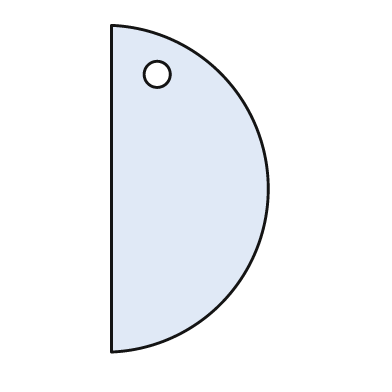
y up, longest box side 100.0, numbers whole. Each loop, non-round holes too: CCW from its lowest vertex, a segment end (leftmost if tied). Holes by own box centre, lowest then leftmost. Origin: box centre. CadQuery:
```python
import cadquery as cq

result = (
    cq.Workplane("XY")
    .moveTo(-24.0, -50.0)
    .threePointArc((24.0, 0.0), (-24.0, 50.0))
    .close()
    .moveTo(-10.0, 35.0)
    .circle(4.0)
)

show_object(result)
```